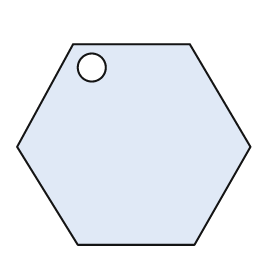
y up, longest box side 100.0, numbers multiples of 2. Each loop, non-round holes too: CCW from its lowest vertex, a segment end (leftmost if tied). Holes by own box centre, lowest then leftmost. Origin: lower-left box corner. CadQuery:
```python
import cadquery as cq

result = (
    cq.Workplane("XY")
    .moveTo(26.0, 0.0)
    .lineTo(76.0, 0.0)
    .lineTo(100.0, 42.0)
    .lineTo(74.0, 86.0)
    .lineTo(24.0, 86.0)
    .lineTo(0.0, 42.0)
    .close()
    .moveTo(32.0, 76.0)
    .circle(6.0)
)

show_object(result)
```